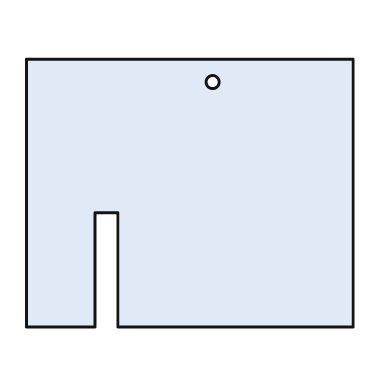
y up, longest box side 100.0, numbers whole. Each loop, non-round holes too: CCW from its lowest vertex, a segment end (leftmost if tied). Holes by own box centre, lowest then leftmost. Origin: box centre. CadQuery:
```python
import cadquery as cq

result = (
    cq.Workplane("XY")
    .moveTo(-50.0, -41.0)
    .lineTo(-29.0, -41.0)
    .lineTo(-29.0, -6.0)
    .lineTo(-22.0, -6.0)
    .lineTo(-22.0, -41.0)
    .lineTo(50.0, -41.0)
    .lineTo(50.0, 41.0)
    .lineTo(-50.0, 41.0)
    .close()
    .moveTo(7.0, 34.0)
    .circle(2.0)
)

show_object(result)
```